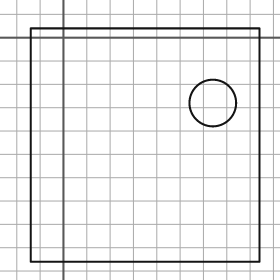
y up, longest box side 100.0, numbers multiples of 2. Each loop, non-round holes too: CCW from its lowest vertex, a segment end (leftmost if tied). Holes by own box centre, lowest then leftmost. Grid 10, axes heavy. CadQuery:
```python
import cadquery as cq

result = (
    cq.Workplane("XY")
    .moveTo(-14.0, -96.0)
    .lineTo(84.0, -96.0)
    .lineTo(84.0, 4.0)
    .lineTo(-14.0, 4.0)
    .close()
    .moveTo(64.0, -28.0)
    .circle(10.0)
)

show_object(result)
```